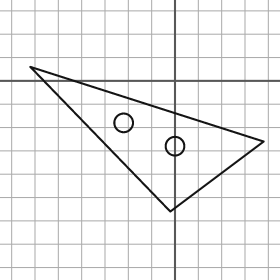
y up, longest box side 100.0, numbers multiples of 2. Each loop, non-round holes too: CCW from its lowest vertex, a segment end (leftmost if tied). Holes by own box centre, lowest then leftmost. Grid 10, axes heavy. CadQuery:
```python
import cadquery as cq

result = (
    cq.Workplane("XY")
    .moveTo(-2.0, -56.0)
    .lineTo(38.0, -26.0)
    .lineTo(-62.0, 6.0)
    .close()
    .moveTo(0.0, -28.0)
    .circle(4.0)
    .moveTo(-22.0, -18.0)
    .circle(4.0)
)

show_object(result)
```